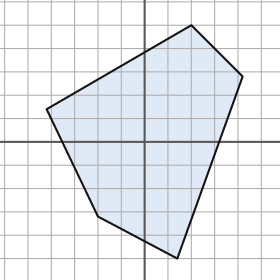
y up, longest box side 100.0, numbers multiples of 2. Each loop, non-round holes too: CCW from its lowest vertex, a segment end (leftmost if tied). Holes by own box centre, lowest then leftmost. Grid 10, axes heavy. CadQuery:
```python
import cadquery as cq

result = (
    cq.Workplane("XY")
    .moveTo(14.0, -50.0)
    .lineTo(42.0, 28.0)
    .lineTo(20.0, 50.0)
    .lineTo(-42.0, 14.0)
    .lineTo(-20.0, -32.0)
    .close()
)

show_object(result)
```